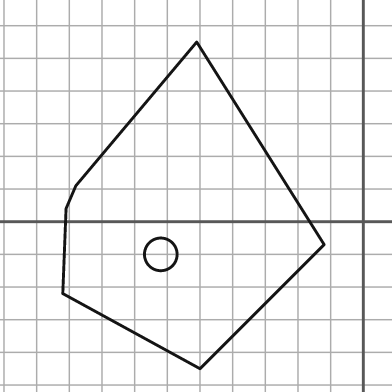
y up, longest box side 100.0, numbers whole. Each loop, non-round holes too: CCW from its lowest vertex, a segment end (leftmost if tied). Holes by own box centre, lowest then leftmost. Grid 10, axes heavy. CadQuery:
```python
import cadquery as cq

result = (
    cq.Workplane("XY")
    .moveTo(-50.0, -45.0)
    .lineTo(-12.0, -7.0)
    .lineTo(-51.0, 55.0)
    .lineTo(-88.0, 11.0)
    .lineTo(-91.0, 4.0)
    .lineTo(-92.0, -22.0)
    .close()
    .moveTo(-62.0, -10.0)
    .circle(5.0)
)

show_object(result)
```